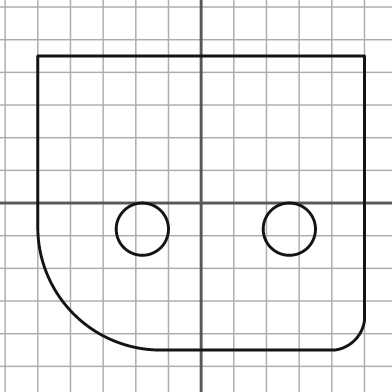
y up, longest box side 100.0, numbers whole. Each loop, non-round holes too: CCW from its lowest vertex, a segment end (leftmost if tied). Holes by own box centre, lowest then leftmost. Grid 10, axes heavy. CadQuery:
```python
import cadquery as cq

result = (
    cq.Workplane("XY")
    .moveTo(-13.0, -45.0)
    .lineTo(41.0, -45.0)
    .threePointArc((47.0, -42.0), (50.0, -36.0))
    .lineTo(50.0, 45.0)
    .lineTo(-50.0, 45.0)
    .lineTo(-50.0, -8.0)
    .threePointArc((-39.0, -34.0), (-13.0, -45.0))
    .close()
    .moveTo(-18.0, -8.0)
    .circle(8.0)
    .moveTo(27.0, -8.0)
    .circle(8.0)
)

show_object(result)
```